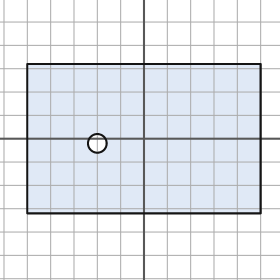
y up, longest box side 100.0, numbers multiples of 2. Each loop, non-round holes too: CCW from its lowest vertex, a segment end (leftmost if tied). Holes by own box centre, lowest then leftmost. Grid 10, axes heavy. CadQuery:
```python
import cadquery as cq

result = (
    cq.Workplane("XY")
    .moveTo(-50.0, -32.0)
    .lineTo(50.0, -32.0)
    .lineTo(50.0, 32.0)
    .lineTo(-50.0, 32.0)
    .close()
    .moveTo(-20.0, -2.0)
    .circle(4.0)
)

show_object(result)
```